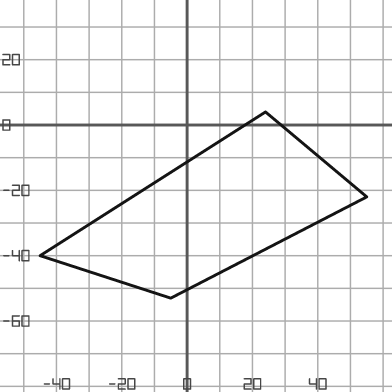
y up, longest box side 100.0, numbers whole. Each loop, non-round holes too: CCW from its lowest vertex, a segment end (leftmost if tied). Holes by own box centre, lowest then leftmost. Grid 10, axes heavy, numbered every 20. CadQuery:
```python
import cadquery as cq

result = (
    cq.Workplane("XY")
    .moveTo(-5.0, -53.0)
    .lineTo(55.0, -22.0)
    .lineTo(24.0, 4.0)
    .lineTo(-45.0, -40.0)
    .close()
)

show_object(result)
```